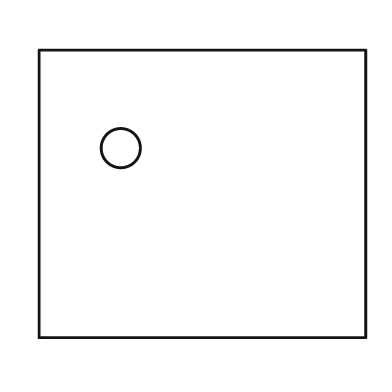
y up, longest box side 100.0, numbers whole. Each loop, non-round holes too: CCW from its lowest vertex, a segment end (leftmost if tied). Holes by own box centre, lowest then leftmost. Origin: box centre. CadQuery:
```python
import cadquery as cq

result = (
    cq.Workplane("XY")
    .moveTo(-50.0, -44.0)
    .lineTo(50.0, -44.0)
    .lineTo(50.0, 44.0)
    .lineTo(-50.0, 44.0)
    .close()
    .moveTo(-25.0, 14.0)
    .circle(6.0)
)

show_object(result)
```